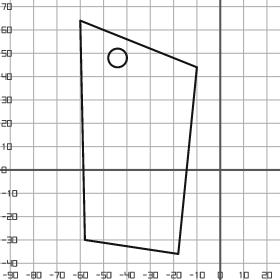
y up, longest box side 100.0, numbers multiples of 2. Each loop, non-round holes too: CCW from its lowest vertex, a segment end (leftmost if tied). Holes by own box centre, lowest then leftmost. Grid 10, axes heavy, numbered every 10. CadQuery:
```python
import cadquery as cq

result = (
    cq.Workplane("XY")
    .moveTo(-18.0, -36.0)
    .lineTo(-10.0, 44.0)
    .lineTo(-60.0, 64.0)
    .lineTo(-58.0, -30.0)
    .close()
    .moveTo(-44.0, 48.0)
    .circle(4.0)
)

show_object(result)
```